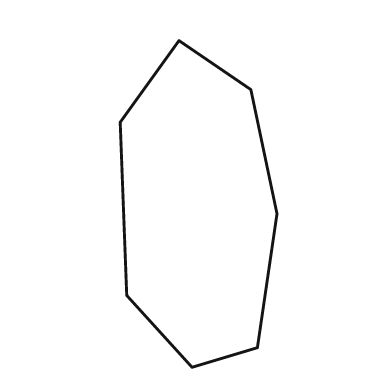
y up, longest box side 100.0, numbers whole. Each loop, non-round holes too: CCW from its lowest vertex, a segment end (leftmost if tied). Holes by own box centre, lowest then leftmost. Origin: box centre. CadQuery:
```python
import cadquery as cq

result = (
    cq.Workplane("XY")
    .moveTo(-2.0, -50.0)
    .lineTo(18.0, -44.0)
    .lineTo(24.0, -3.0)
    .lineTo(16.0, 35.0)
    .lineTo(-6.0, 50.0)
    .lineTo(-24.0, 25.0)
    .lineTo(-22.0, -28.0)
    .close()
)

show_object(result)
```